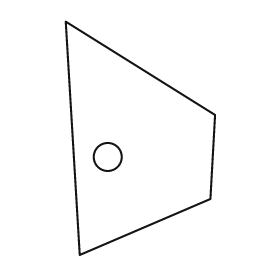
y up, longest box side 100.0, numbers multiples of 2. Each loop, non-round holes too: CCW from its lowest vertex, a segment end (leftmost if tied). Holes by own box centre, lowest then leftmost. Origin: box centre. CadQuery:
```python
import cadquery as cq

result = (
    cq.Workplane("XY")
    .moveTo(-26.0, -50.0)
    .lineTo(30.0, -26.0)
    .lineTo(32.0, 10.0)
    .lineTo(-32.0, 50.0)
    .close()
    .moveTo(-14.0, -8.0)
    .circle(6.0)
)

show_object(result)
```